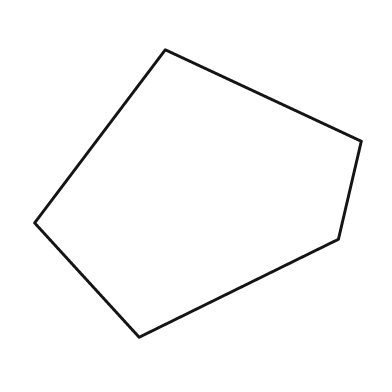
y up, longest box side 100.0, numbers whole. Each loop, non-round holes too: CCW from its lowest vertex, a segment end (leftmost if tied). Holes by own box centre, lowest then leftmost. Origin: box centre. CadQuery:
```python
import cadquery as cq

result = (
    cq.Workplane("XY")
    .moveTo(-18.0, -44.0)
    .lineTo(43.0, -14.0)
    .lineTo(50.0, 16.0)
    .lineTo(-10.0, 44.0)
    .lineTo(-50.0, -9.0)
    .close()
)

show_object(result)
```